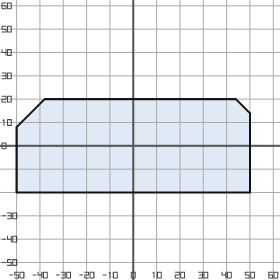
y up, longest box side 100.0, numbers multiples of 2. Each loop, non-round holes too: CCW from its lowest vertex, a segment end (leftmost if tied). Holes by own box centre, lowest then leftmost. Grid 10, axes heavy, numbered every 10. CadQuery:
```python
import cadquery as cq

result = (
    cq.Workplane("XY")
    .moveTo(-50.0, -20.0)
    .lineTo(50.0, -20.0)
    .lineTo(50.0, 14.0)
    .lineTo(44.0, 20.0)
    .lineTo(-38.0, 20.0)
    .lineTo(-50.0, 8.0)
    .close()
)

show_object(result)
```